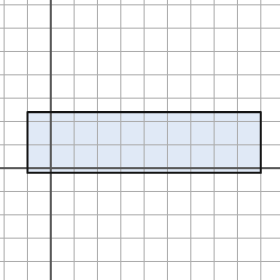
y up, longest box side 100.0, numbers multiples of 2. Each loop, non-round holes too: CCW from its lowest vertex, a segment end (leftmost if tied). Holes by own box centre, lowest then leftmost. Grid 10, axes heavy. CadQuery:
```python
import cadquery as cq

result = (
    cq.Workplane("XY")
    .moveTo(-10.0, -2.0)
    .lineTo(90.0, -2.0)
    .lineTo(90.0, 24.0)
    .lineTo(-10.0, 24.0)
    .close()
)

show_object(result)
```